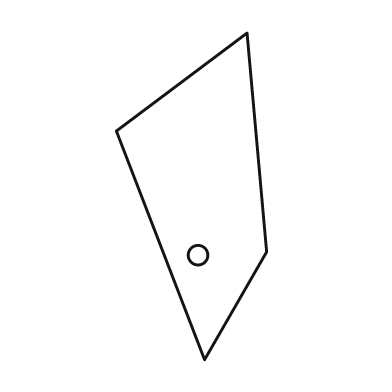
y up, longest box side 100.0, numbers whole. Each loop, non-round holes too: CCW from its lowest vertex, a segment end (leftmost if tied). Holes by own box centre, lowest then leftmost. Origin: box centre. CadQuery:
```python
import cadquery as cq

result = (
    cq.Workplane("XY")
    .moveTo(4.0, -50.0)
    .lineTo(23.0, -17.0)
    .lineTo(17.0, 50.0)
    .lineTo(-23.0, 20.0)
    .close()
    .moveTo(2.0, -18.0)
    .circle(3.0)
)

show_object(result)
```